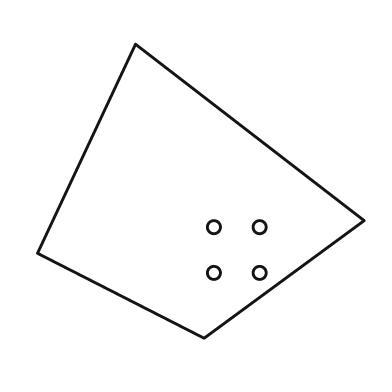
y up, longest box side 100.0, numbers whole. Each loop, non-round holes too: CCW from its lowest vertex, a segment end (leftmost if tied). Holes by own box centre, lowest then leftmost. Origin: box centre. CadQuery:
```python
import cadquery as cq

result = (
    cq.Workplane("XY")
    .moveTo(1.0, -45.0)
    .lineTo(50.0, -9.0)
    .lineTo(-20.0, 45.0)
    .lineTo(-50.0, -19.0)
    .close()
    .moveTo(4.0, -25.0)
    .circle(2.0)
    .moveTo(18.0, -25.0)
    .circle(2.0)
    .moveTo(4.0, -11.0)
    .circle(2.0)
    .moveTo(18.0, -11.0)
    .circle(2.0)
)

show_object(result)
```